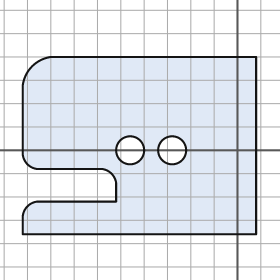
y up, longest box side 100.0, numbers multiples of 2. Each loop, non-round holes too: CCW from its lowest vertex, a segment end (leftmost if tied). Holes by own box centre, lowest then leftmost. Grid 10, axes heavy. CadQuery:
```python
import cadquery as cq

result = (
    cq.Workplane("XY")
    .moveTo(-92.0, -36.0)
    .lineTo(8.0, -36.0)
    .lineTo(8.0, 40.0)
    .lineTo(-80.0, 40.0)
    .threePointArc((-88.0, 36.0), (-92.0, 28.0))
    .lineTo(-92.0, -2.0)
    .threePointArc((-90.0, -6.0), (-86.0, -8.0))
    .lineTo(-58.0, -8.0)
    .threePointArc((-54.0, -10.0), (-52.0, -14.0))
    .lineTo(-52.0, -22.0)
    .lineTo(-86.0, -22.0)
    .threePointArc((-90.0, -24.0), (-92.0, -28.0))
    .close()
    .moveTo(-46.0, 0.0)
    .circle(6.0)
    .moveTo(-28.0, 0.0)
    .circle(6.0)
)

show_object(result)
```